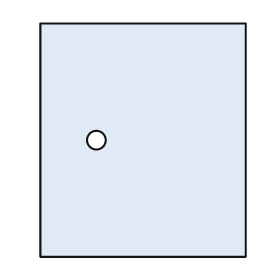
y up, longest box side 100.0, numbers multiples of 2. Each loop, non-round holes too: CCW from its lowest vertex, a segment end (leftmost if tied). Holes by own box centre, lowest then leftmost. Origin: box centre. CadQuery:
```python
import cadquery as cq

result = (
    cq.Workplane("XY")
    .moveTo(-44.0, -50.0)
    .lineTo(44.0, -50.0)
    .lineTo(44.0, 50.0)
    .lineTo(-44.0, 50.0)
    .close()
    .moveTo(-20.0, 0.0)
    .circle(4.0)
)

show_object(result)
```